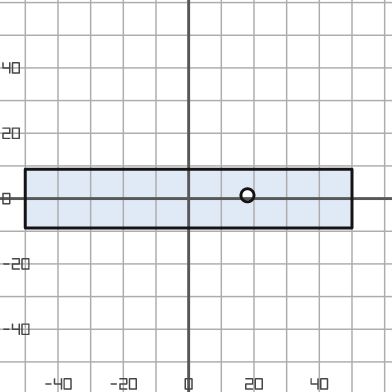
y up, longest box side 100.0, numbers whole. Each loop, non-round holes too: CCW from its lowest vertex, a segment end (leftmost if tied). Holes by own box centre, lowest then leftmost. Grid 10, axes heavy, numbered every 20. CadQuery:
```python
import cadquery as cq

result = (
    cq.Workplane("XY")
    .moveTo(-50.0, -9.0)
    .lineTo(50.0, -9.0)
    .lineTo(50.0, 9.0)
    .lineTo(-50.0, 9.0)
    .close()
    .moveTo(18.0, 1.0)
    .circle(2.0)
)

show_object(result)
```